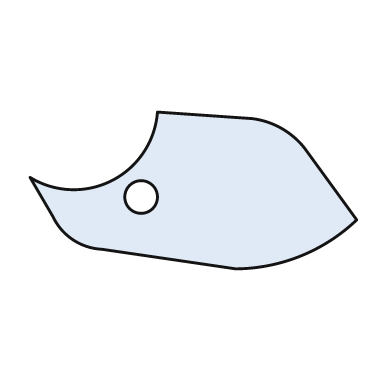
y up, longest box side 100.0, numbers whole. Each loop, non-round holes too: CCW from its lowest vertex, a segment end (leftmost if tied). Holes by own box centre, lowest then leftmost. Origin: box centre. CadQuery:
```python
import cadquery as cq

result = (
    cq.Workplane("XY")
    .moveTo(13.0, -24.0)
    .threePointArc((33.0, -20.0), (50.0, -9.0))
    .lineTo(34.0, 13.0)
    .threePointArc((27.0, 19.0), (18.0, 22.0))
    .lineTo(-11.0, 24.0)
    .threePointArc((-25.0, 3.0), (-50.0, 4.0))
    .lineTo(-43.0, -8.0)
    .threePointArc((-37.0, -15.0), (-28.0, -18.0))
    .close()
    .moveTo(-16.0, -2.0)
    .circle(5.0)
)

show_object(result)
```